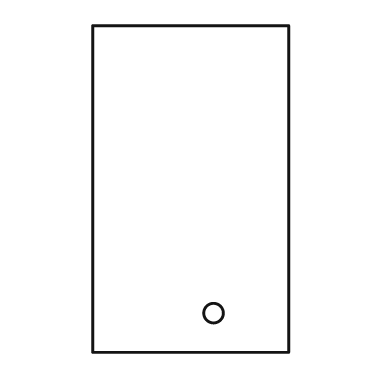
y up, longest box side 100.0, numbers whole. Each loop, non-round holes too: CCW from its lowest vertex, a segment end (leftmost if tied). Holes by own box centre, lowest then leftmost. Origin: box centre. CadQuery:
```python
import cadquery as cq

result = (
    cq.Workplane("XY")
    .moveTo(-30.0, -50.0)
    .lineTo(30.0, -50.0)
    .lineTo(30.0, 50.0)
    .lineTo(-30.0, 50.0)
    .close()
    .moveTo(7.0, -38.0)
    .circle(3.0)
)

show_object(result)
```